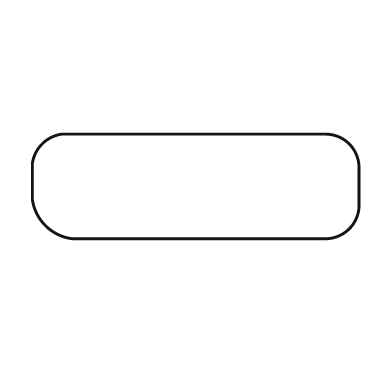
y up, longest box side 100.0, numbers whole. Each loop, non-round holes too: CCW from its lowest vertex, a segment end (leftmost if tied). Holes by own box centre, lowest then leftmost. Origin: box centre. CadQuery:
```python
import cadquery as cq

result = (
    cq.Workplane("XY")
    .moveTo(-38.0, -16.0)
    .lineTo(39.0, -16.0)
    .threePointArc((47.0, -13.0), (50.0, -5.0))
    .lineTo(50.0, 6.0)
    .threePointArc((47.0, 13.0), (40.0, 16.0))
    .lineTo(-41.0, 16.0)
    .threePointArc((-47.0, 13.0), (-50.0, 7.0))
    .lineTo(-50.0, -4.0)
    .threePointArc((-46.0, -12.0), (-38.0, -16.0))
    .close()
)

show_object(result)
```